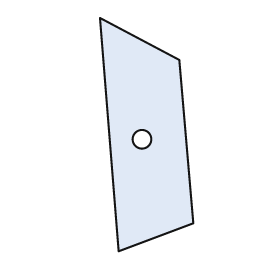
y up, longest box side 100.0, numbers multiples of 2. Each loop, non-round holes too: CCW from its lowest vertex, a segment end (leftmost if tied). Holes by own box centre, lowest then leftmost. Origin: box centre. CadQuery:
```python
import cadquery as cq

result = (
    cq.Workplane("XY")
    .moveTo(-12.0, -50.0)
    .lineTo(20.0, -38.0)
    .lineTo(14.0, 32.0)
    .lineTo(-20.0, 50.0)
    .close()
    .moveTo(-2.0, -2.0)
    .circle(4.0)
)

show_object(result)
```